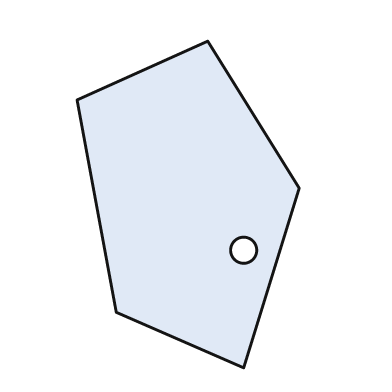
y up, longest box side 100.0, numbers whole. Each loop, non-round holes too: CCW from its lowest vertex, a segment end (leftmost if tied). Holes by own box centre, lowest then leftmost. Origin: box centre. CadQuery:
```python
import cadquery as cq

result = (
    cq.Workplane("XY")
    .moveTo(17.0, -50.0)
    .lineTo(34.0, 5.0)
    .lineTo(6.0, 50.0)
    .lineTo(-34.0, 32.0)
    .lineTo(-22.0, -33.0)
    .close()
    .moveTo(17.0, -14.0)
    .circle(4.0)
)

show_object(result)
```